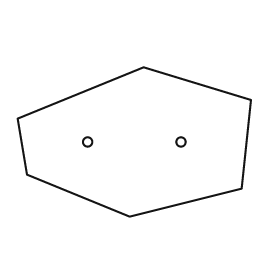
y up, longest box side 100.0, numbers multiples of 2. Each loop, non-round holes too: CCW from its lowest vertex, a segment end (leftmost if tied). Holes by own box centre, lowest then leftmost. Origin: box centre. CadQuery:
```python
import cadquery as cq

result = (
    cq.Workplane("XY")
    .moveTo(-2.0, -32.0)
    .lineTo(46.0, -20.0)
    .lineTo(50.0, 18.0)
    .lineTo(4.0, 32.0)
    .lineTo(-50.0, 10.0)
    .lineTo(-46.0, -14.0)
    .close()
    .moveTo(-20.0, 0.0)
    .circle(2.0)
    .moveTo(20.0, 0.0)
    .circle(2.0)
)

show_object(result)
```